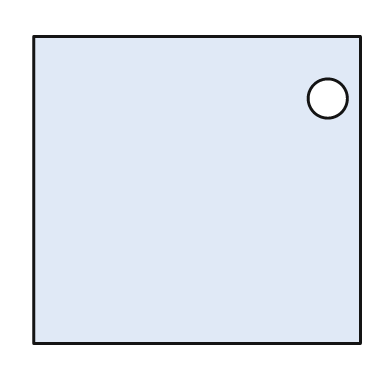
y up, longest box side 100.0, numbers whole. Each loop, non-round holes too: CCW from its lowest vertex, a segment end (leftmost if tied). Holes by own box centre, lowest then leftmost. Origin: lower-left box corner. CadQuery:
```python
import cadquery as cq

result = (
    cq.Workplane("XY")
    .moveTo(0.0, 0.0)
    .lineTo(100.0, 0.0)
    .lineTo(100.0, 94.0)
    .lineTo(0.0, 94.0)
    .close()
    .moveTo(90.0, 75.0)
    .circle(6.0)
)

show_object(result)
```